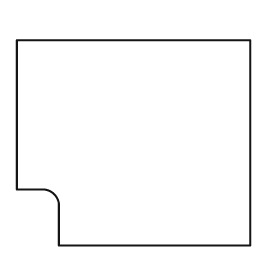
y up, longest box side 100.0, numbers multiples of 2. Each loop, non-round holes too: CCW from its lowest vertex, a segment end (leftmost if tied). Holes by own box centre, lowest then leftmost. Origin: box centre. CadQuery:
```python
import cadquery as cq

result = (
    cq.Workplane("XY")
    .moveTo(-32.0, -44.0)
    .lineTo(50.0, -44.0)
    .lineTo(50.0, 44.0)
    .lineTo(-50.0, 44.0)
    .lineTo(-50.0, -20.0)
    .lineTo(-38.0, -20.0)
    .threePointArc((-34.0, -22.0), (-32.0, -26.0))
    .close()
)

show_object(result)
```